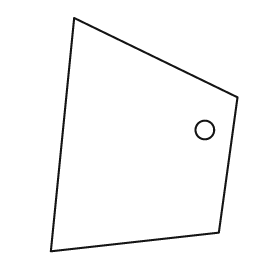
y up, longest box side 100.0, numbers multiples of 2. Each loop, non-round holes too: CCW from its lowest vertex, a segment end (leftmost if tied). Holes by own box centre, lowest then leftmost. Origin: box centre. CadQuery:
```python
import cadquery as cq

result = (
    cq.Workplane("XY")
    .moveTo(-40.0, -50.0)
    .lineTo(32.0, -42.0)
    .lineTo(40.0, 16.0)
    .lineTo(-30.0, 50.0)
    .close()
    .moveTo(26.0, 2.0)
    .circle(4.0)
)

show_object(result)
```